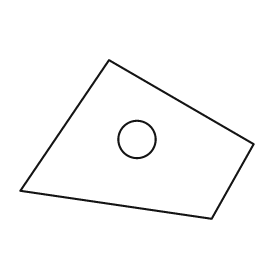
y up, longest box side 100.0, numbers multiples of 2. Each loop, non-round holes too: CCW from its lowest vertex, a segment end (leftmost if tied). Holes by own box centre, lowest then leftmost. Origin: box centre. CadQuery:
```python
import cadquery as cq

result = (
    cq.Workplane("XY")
    .moveTo(32.0, -34.0)
    .lineTo(50.0, -2.0)
    .lineTo(-12.0, 34.0)
    .lineTo(-50.0, -22.0)
    .close()
    .moveTo(0.0, 0.0)
    .circle(8.0)
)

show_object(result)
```